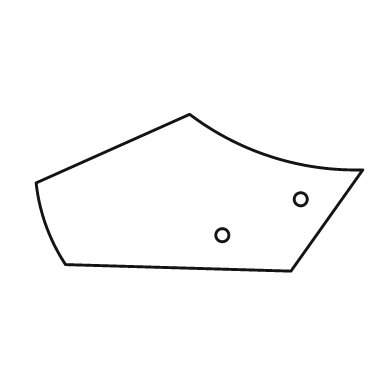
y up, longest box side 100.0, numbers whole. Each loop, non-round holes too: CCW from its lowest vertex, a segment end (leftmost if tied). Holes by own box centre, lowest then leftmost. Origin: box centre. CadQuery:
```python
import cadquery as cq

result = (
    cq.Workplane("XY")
    .moveTo(28.0, -24.0)
    .lineTo(50.0, 7.0)
    .threePointArc((22.0, 11.0), (-3.0, 24.0))
    .lineTo(-50.0, 3.0)
    .threePointArc((-47.0, -10.0), (-41.0, -22.0))
    .close()
    .moveTo(7.0, -13.0)
    .circle(2.0)
    .moveTo(31.0, -2.0)
    .circle(2.0)
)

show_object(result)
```